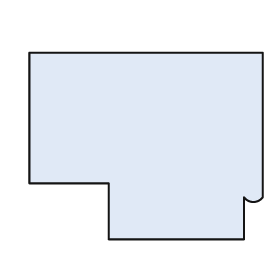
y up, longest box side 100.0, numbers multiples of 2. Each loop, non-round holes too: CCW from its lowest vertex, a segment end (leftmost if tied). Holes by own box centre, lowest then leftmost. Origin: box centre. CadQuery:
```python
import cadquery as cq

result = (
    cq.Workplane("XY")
    .moveTo(-16.0, -40.0)
    .lineTo(42.0, -40.0)
    .lineTo(42.0, -22.0)
    .threePointArc((46.0, -24.0), (50.0, -22.0))
    .lineTo(50.0, 40.0)
    .lineTo(-50.0, 40.0)
    .lineTo(-50.0, -16.0)
    .lineTo(-16.0, -16.0)
    .close()
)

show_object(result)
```